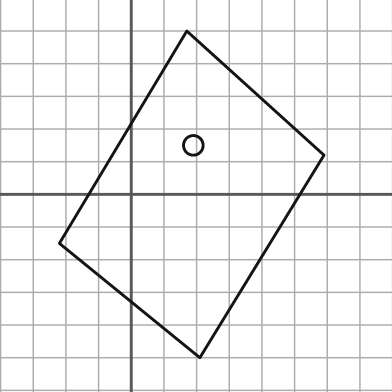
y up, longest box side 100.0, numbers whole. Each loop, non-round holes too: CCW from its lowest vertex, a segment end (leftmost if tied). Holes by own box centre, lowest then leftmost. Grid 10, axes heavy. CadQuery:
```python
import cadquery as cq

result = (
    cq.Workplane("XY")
    .moveTo(21.0, -50.0)
    .lineTo(59.0, 12.0)
    .lineTo(17.0, 50.0)
    .lineTo(-22.0, -15.0)
    .close()
    .moveTo(19.0, 15.0)
    .circle(3.0)
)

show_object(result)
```